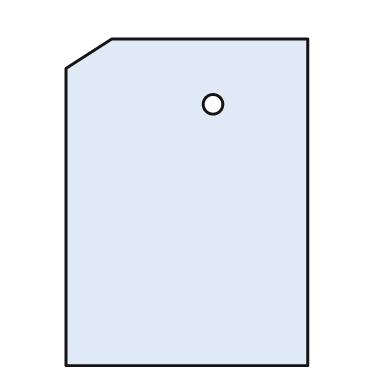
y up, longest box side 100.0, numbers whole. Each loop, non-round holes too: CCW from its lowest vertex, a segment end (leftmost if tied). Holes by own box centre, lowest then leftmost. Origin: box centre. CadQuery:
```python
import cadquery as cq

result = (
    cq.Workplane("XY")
    .moveTo(-37.0, -50.0)
    .lineTo(37.0, -50.0)
    .lineTo(37.0, 50.0)
    .lineTo(-23.0, 50.0)
    .lineTo(-37.0, 41.0)
    .close()
    .moveTo(8.0, 30.0)
    .circle(3.0)
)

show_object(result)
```